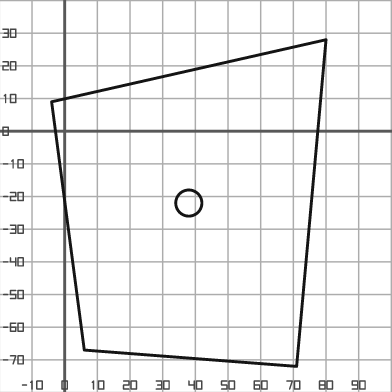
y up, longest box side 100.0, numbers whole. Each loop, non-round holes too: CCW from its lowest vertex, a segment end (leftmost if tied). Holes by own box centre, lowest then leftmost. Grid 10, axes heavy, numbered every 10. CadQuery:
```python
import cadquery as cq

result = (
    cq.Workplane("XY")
    .moveTo(71.0, -72.0)
    .lineTo(80.0, 28.0)
    .lineTo(-4.0, 9.0)
    .lineTo(6.0, -67.0)
    .close()
    .moveTo(38.0, -22.0)
    .circle(4.0)
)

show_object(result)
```